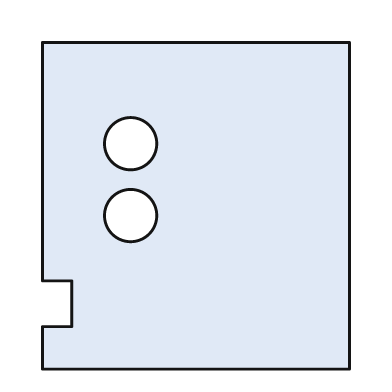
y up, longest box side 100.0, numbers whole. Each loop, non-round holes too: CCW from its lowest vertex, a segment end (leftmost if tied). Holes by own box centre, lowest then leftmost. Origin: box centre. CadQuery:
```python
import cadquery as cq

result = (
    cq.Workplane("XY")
    .moveTo(-47.0, -50.0)
    .lineTo(47.0, -50.0)
    .lineTo(47.0, 50.0)
    .lineTo(-47.0, 50.0)
    .lineTo(-47.0, -23.0)
    .lineTo(-38.0, -23.0)
    .lineTo(-38.0, -37.0)
    .lineTo(-47.0, -37.0)
    .close()
    .moveTo(-20.0, -3.0)
    .circle(8.0)
    .moveTo(-20.0, 19.0)
    .circle(8.0)
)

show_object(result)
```